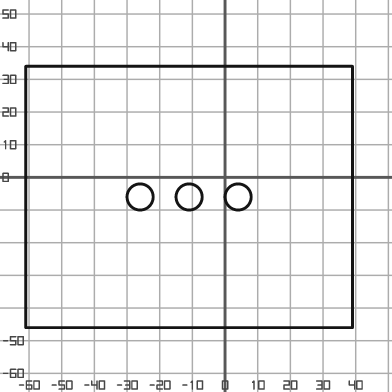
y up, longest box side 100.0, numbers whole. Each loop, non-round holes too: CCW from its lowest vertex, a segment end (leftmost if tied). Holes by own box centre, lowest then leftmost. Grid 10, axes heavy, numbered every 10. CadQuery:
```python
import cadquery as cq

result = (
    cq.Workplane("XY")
    .moveTo(-61.0, -46.0)
    .lineTo(39.0, -46.0)
    .lineTo(39.0, 34.0)
    .lineTo(-61.0, 34.0)
    .close()
    .moveTo(-26.0, -6.0)
    .circle(4.0)
    .moveTo(-11.0, -6.0)
    .circle(4.0)
    .moveTo(4.0, -6.0)
    .circle(4.0)
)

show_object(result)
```